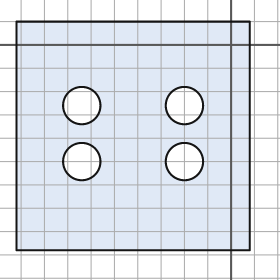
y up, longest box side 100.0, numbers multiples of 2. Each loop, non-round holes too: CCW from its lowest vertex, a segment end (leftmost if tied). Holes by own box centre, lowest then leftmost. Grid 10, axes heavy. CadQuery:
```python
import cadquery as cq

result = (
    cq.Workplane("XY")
    .moveTo(-92.0, -88.0)
    .lineTo(8.0, -88.0)
    .lineTo(8.0, 10.0)
    .lineTo(-92.0, 10.0)
    .close()
    .moveTo(-64.0, -50.0)
    .circle(8.0)
    .moveTo(-20.0, -50.0)
    .circle(8.0)
    .moveTo(-64.0, -26.0)
    .circle(8.0)
    .moveTo(-20.0, -26.0)
    .circle(8.0)
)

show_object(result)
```